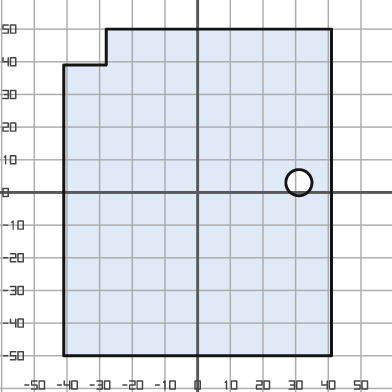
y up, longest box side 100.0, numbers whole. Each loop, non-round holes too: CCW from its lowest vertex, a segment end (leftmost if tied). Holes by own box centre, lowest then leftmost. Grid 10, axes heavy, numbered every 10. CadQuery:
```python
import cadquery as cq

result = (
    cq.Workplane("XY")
    .moveTo(-41.0, -50.0)
    .lineTo(41.0, -50.0)
    .lineTo(41.0, 50.0)
    .lineTo(-28.0, 50.0)
    .lineTo(-28.0, 39.0)
    .lineTo(-41.0, 39.0)
    .close()
    .moveTo(31.0, 3.0)
    .circle(4.0)
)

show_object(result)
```